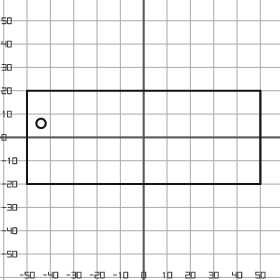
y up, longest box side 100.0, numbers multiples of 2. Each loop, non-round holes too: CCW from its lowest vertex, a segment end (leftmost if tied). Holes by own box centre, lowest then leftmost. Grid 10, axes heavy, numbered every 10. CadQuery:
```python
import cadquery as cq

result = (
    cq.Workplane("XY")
    .moveTo(-50.0, -20.0)
    .lineTo(50.0, -20.0)
    .lineTo(50.0, 20.0)
    .lineTo(-50.0, 20.0)
    .close()
    .moveTo(-44.0, 6.0)
    .circle(2.0)
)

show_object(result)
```